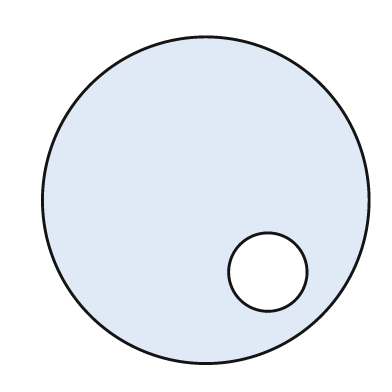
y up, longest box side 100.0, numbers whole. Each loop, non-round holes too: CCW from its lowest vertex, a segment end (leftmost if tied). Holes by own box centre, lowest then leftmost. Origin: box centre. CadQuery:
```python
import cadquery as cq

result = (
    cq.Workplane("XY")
    .moveTo(0.0, 0.0)
    .circle(50.0)
    .moveTo(19.0, -22.0)
    .circle(12.0)
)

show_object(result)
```